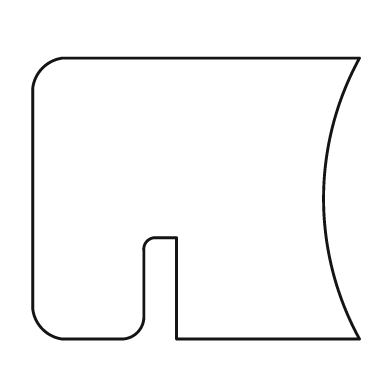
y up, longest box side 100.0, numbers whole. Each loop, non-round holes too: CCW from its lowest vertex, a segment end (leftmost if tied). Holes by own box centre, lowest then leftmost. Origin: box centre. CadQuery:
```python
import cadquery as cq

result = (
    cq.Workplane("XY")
    .moveTo(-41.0, -43.0)
    .lineTo(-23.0, -43.0)
    .threePointArc((-18.0, -41.0), (-16.0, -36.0))
    .lineTo(-16.0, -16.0)
    .threePointArc((-15.0, -13.0), (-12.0, -12.0))
    .lineTo(-6.0, -12.0)
    .lineTo(-6.0, -43.0)
    .lineTo(50.0, -43.0)
    .threePointArc((39.0, 0.0), (50.0, 43.0))
    .lineTo(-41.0, 43.0)
    .threePointArc((-47.0, 40.0), (-50.0, 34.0))
    .lineTo(-50.0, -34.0)
    .threePointArc((-47.0, -40.0), (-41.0, -43.0))
    .close()
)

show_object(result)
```